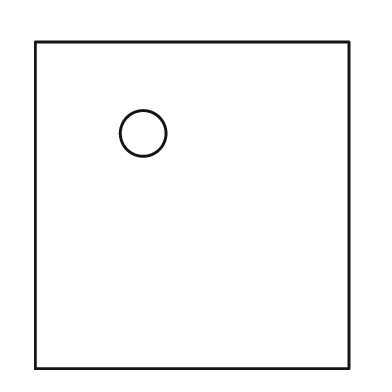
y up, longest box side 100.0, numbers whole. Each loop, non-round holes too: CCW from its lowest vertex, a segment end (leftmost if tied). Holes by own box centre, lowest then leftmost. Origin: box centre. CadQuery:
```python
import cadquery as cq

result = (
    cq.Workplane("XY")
    .moveTo(-48.0, -50.0)
    .lineTo(48.0, -50.0)
    .lineTo(48.0, 50.0)
    .lineTo(-48.0, 50.0)
    .close()
    .moveTo(-15.0, 22.0)
    .circle(7.0)
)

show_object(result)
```